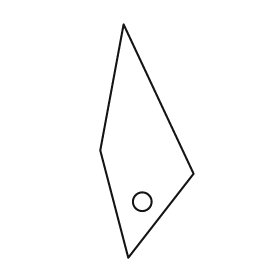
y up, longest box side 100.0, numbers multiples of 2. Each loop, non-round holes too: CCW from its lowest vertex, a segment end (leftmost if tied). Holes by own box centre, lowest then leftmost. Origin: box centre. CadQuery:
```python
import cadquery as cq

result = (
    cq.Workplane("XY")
    .moveTo(-8.0, -50.0)
    .lineTo(20.0, -14.0)
    .lineTo(-10.0, 50.0)
    .lineTo(-20.0, -4.0)
    .close()
    .moveTo(-2.0, -26.0)
    .circle(4.0)
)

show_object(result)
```